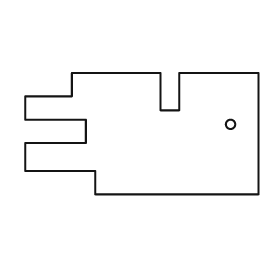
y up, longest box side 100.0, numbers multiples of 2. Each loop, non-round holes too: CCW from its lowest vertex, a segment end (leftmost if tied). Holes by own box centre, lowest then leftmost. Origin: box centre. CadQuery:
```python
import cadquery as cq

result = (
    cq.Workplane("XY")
    .moveTo(-20.0, -26.0)
    .lineTo(50.0, -26.0)
    .lineTo(50.0, 26.0)
    .lineTo(16.0, 26.0)
    .lineTo(16.0, 10.0)
    .lineTo(8.0, 10.0)
    .lineTo(8.0, 26.0)
    .lineTo(-30.0, 26.0)
    .lineTo(-30.0, 16.0)
    .lineTo(-50.0, 16.0)
    .lineTo(-50.0, 6.0)
    .lineTo(-24.0, 6.0)
    .lineTo(-24.0, -4.0)
    .lineTo(-50.0, -4.0)
    .lineTo(-50.0, -16.0)
    .lineTo(-20.0, -16.0)
    .close()
    .moveTo(38.0, 4.0)
    .circle(2.0)
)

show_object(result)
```